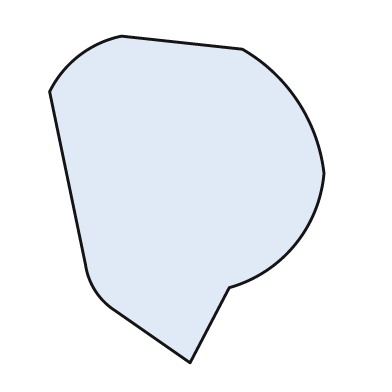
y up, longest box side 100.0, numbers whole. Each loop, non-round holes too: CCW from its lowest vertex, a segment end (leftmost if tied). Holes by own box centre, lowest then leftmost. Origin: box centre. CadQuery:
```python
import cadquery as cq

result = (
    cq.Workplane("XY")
    .moveTo(1.0, -50.0)
    .lineTo(13.0, -27.0)
    .threePointArc((33.0, -14.0), (42.0, 8.0))
    .threePointArc((34.0, 30.0), (17.0, 46.0))
    .lineTo(-20.0, 50.0)
    .threePointArc((-33.0, 44.0), (-42.0, 33.0))
    .lineTo(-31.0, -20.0)
    .threePointArc((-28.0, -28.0), (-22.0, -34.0))
    .close()
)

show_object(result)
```